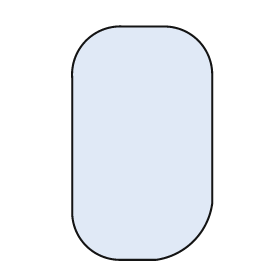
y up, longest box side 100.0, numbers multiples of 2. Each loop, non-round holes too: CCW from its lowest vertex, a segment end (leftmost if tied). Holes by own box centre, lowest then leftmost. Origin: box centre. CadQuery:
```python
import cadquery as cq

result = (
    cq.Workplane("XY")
    .moveTo(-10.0, -50.0)
    .lineTo(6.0, -50.0)
    .threePointArc((22.0, -42.0), (30.0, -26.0))
    .lineTo(30.0, 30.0)
    .threePointArc((24.0, 44.0), (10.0, 50.0))
    .lineTo(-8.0, 50.0)
    .threePointArc((-24.0, 44.0), (-30.0, 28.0))
    .lineTo(-30.0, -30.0)
    .threePointArc((-24.0, -44.0), (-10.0, -50.0))
    .close()
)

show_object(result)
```